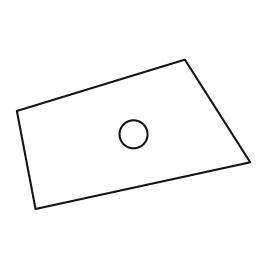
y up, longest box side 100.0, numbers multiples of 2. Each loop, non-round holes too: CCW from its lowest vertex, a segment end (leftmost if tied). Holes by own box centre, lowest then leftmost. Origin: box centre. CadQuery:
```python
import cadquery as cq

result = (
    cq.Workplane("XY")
    .moveTo(-42.0, -32.0)
    .lineTo(50.0, -12.0)
    .lineTo(22.0, 32.0)
    .lineTo(-50.0, 10.0)
    .close()
    .moveTo(0.0, 0.0)
    .circle(6.0)
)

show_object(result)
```